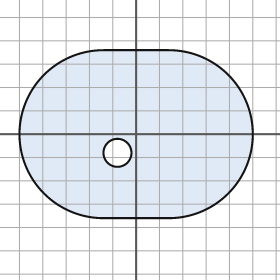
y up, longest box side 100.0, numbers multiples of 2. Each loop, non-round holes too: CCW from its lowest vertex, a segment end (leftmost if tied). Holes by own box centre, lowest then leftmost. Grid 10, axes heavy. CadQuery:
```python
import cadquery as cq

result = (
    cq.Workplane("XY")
    .moveTo(-14.0, -36.0)
    .lineTo(14.0, -36.0)
    .threePointArc((50.0, 0.0), (14.0, 36.0))
    .lineTo(-14.0, 36.0)
    .threePointArc((-50.0, 0.0), (-14.0, -36.0))
    .close()
    .moveTo(-8.0, -8.0)
    .circle(6.0)
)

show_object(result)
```